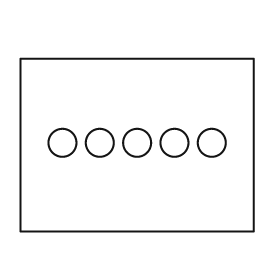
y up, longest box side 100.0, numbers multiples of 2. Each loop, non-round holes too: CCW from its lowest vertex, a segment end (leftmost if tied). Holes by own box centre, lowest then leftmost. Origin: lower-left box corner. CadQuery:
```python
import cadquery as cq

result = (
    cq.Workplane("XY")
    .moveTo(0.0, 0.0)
    .lineTo(100.0, 0.0)
    .lineTo(100.0, 74.0)
    .lineTo(0.0, 74.0)
    .close()
    .moveTo(18.0, 38.0)
    .circle(6.0)
    .moveTo(34.0, 38.0)
    .circle(6.0)
    .moveTo(50.0, 38.0)
    .circle(6.0)
    .moveTo(66.0, 38.0)
    .circle(6.0)
    .moveTo(82.0, 38.0)
    .circle(6.0)
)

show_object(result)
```